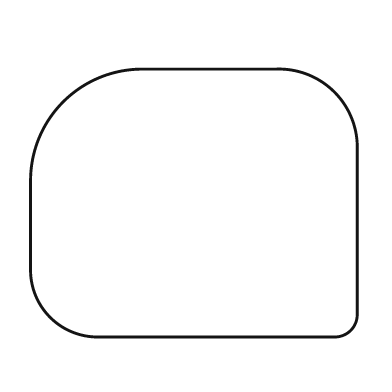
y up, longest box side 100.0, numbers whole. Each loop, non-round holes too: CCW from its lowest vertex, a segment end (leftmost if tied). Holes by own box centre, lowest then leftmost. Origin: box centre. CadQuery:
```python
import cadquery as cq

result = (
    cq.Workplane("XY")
    .moveTo(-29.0, -41.0)
    .lineTo(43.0, -41.0)
    .threePointArc((48.0, -39.0), (50.0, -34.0))
    .lineTo(50.0, 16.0)
    .threePointArc((43.0, 34.0), (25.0, 41.0))
    .lineTo(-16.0, 41.0)
    .threePointArc((-40.0, 31.0), (-50.0, 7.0))
    .lineTo(-50.0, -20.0)
    .threePointArc((-44.0, -35.0), (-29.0, -41.0))
    .close()
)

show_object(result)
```